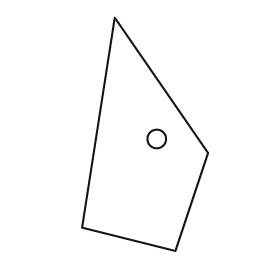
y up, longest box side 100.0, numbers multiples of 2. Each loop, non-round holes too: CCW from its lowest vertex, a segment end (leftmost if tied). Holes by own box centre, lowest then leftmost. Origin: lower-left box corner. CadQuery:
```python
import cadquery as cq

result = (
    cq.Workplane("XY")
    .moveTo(40.0, 0.0)
    .lineTo(54.0, 42.0)
    .lineTo(14.0, 100.0)
    .lineTo(0.0, 10.0)
    .close()
    .moveTo(32.0, 48.0)
    .circle(4.0)
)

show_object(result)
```